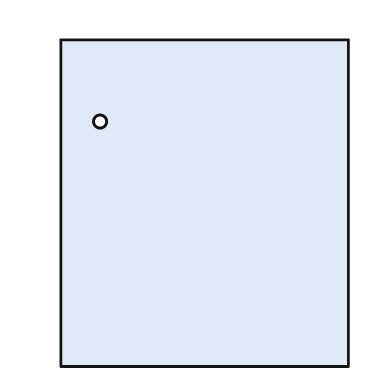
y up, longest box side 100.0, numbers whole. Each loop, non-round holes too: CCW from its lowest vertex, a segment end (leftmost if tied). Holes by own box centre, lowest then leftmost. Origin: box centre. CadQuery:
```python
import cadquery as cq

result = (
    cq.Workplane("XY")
    .moveTo(-44.0, -50.0)
    .lineTo(44.0, -50.0)
    .lineTo(44.0, 50.0)
    .lineTo(-44.0, 50.0)
    .close()
    .moveTo(-32.0, 25.0)
    .circle(2.0)
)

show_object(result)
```